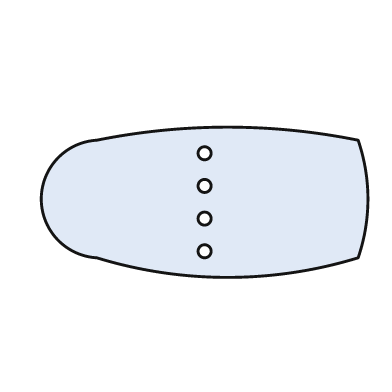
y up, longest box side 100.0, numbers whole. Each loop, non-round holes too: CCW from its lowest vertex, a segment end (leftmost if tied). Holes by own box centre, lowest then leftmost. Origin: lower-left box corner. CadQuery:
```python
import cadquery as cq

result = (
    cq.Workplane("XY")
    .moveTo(17.0, 6.0)
    .threePointArc((57.0, 0.0), (97.0, 6.0))
    .threePointArc((100.0, 24.0), (97.0, 42.0))
    .threePointArc((57.0, 46.0), (17.0, 42.0))
    .threePointArc((0.0, 24.0), (17.0, 6.0))
    .close()
    .moveTo(50.0, 8.0)
    .circle(2.0)
    .moveTo(50.0, 18.0)
    .circle(2.0)
    .moveTo(50.0, 28.0)
    .circle(2.0)
    .moveTo(50.0, 38.0)
    .circle(2.0)
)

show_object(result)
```